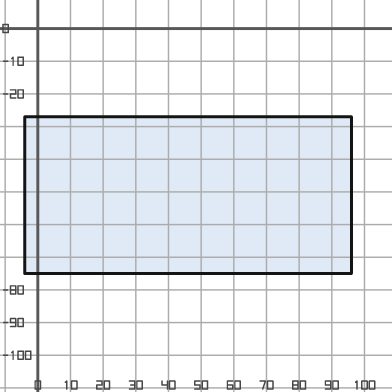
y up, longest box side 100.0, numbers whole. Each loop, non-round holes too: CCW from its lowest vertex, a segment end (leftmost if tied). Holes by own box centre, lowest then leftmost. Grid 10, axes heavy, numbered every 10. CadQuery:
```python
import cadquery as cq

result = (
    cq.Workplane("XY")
    .moveTo(-4.0, -75.0)
    .lineTo(96.0, -75.0)
    .lineTo(96.0, -27.0)
    .lineTo(-4.0, -27.0)
    .close()
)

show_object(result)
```